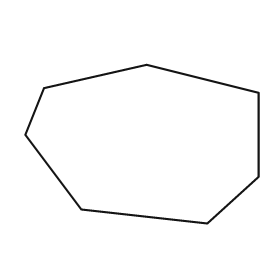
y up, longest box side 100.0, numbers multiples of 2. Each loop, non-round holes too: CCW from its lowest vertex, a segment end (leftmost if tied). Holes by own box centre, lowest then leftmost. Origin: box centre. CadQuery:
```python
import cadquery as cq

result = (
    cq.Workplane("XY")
    .moveTo(28.0, -34.0)
    .lineTo(50.0, -14.0)
    .lineTo(50.0, 22.0)
    .lineTo(2.0, 34.0)
    .lineTo(-42.0, 24.0)
    .lineTo(-50.0, 4.0)
    .lineTo(-26.0, -28.0)
    .close()
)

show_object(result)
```